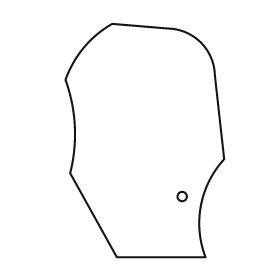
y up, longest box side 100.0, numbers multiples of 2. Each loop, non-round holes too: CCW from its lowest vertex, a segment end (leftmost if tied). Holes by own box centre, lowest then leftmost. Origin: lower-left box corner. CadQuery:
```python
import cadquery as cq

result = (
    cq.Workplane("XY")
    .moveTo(22.0, 0.0)
    .lineTo(60.0, 0.0)
    .threePointArc((58.0, 22.0), (68.0, 42.0))
    .lineTo(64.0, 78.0)
    .threePointArc((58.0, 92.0), (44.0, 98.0))
    .lineTo(20.0, 100.0)
    .threePointArc((8.0, 90.0), (0.0, 76.0))
    .threePointArc((4.0, 56.0), (2.0, 36.0))
    .close()
    .moveTo(50.0, 26.0)
    .circle(2.0)
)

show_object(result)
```